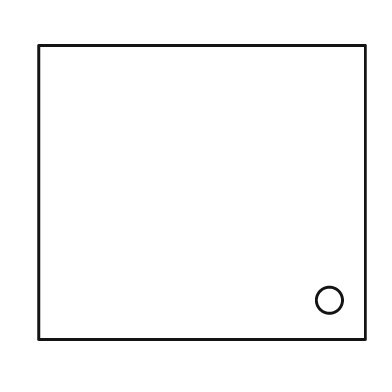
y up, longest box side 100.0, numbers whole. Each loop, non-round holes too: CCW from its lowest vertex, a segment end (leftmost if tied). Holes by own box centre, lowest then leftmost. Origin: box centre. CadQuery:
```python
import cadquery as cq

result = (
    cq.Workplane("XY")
    .moveTo(-50.0, -45.0)
    .lineTo(50.0, -45.0)
    .lineTo(50.0, 45.0)
    .lineTo(-50.0, 45.0)
    .close()
    .moveTo(39.0, -33.0)
    .circle(4.0)
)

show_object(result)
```